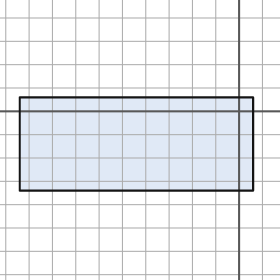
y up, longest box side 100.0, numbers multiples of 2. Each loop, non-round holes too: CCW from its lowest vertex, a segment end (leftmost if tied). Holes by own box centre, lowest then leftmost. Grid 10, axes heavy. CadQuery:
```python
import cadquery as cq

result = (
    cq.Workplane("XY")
    .moveTo(-94.0, -34.0)
    .lineTo(6.0, -34.0)
    .lineTo(6.0, 6.0)
    .lineTo(-94.0, 6.0)
    .close()
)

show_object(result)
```